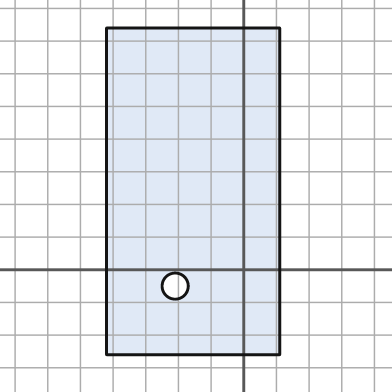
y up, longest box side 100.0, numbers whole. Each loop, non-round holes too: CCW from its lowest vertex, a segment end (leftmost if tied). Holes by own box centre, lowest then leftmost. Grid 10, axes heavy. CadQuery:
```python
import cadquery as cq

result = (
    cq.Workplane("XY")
    .moveTo(-42.0, -26.0)
    .lineTo(11.0, -26.0)
    .lineTo(11.0, 74.0)
    .lineTo(-42.0, 74.0)
    .close()
    .moveTo(-21.0, -5.0)
    .circle(4.0)
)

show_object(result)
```